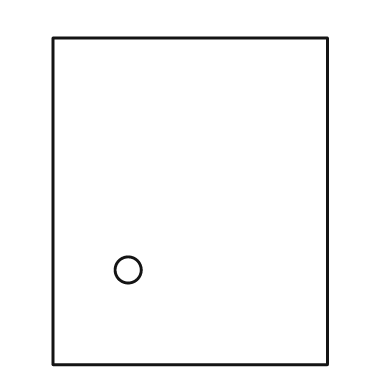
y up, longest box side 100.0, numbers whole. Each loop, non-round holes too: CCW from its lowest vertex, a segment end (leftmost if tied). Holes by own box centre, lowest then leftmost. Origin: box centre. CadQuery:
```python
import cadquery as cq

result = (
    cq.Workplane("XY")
    .moveTo(-42.0, -50.0)
    .lineTo(42.0, -50.0)
    .lineTo(42.0, 50.0)
    .lineTo(-42.0, 50.0)
    .close()
    .moveTo(-19.0, -21.0)
    .circle(4.0)
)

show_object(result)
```